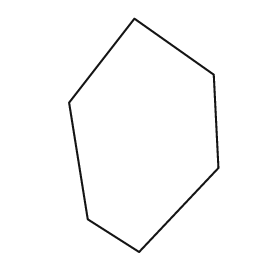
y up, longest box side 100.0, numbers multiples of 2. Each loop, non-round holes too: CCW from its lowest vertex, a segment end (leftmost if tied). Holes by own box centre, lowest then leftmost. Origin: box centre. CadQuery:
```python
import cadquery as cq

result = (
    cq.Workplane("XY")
    .moveTo(-2.0, -50.0)
    .lineTo(32.0, -14.0)
    .lineTo(30.0, 26.0)
    .lineTo(-4.0, 50.0)
    .lineTo(-32.0, 14.0)
    .lineTo(-24.0, -36.0)
    .close()
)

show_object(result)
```